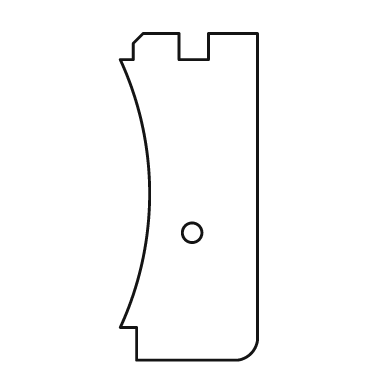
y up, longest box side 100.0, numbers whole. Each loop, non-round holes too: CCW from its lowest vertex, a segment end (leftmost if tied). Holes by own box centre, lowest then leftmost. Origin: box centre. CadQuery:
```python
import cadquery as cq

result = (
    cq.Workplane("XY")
    .moveTo(-16.0, -50.0)
    .lineTo(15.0, -50.0)
    .threePointArc((19.0, -48.0), (21.0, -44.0))
    .lineTo(21.0, 50.0)
    .lineTo(6.0, 50.0)
    .lineTo(6.0, 42.0)
    .lineTo(-3.0, 42.0)
    .lineTo(-3.0, 50.0)
    .lineTo(-14.0, 50.0)
    .lineTo(-17.0, 47.0)
    .lineTo(-17.0, 42.0)
    .lineTo(-21.0, 42.0)
    .threePointArc((-12.0, 1.0), (-21.0, -40.0))
    .lineTo(-16.0, -40.0)
    .close()
    .moveTo(1.0, -11.0)
    .circle(3.0)
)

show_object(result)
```